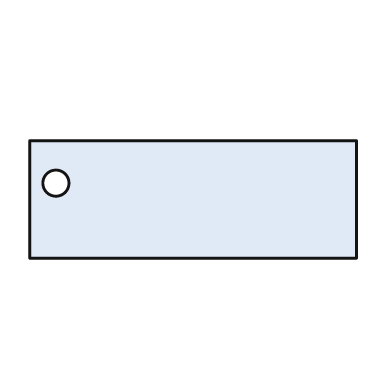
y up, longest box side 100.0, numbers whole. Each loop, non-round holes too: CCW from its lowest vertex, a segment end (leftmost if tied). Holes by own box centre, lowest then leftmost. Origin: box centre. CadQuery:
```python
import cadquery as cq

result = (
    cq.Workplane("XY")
    .moveTo(-50.0, -18.0)
    .lineTo(50.0, -18.0)
    .lineTo(50.0, 18.0)
    .lineTo(-50.0, 18.0)
    .close()
    .moveTo(-42.0, 5.0)
    .circle(4.0)
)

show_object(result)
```